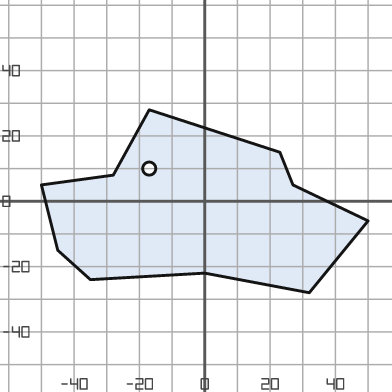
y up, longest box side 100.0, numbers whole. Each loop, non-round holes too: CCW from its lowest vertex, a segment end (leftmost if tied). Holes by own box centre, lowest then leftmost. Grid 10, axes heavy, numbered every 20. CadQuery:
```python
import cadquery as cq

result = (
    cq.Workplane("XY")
    .moveTo(32.0, -28.0)
    .lineTo(50.0, -6.0)
    .lineTo(27.0, 5.0)
    .lineTo(23.0, 15.0)
    .lineTo(-17.0, 28.0)
    .lineTo(-28.0, 8.0)
    .lineTo(-50.0, 5.0)
    .lineTo(-45.0, -15.0)
    .lineTo(-35.0, -24.0)
    .lineTo(0.0, -22.0)
    .close()
    .moveTo(-17.0, 10.0)
    .circle(2.0)
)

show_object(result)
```